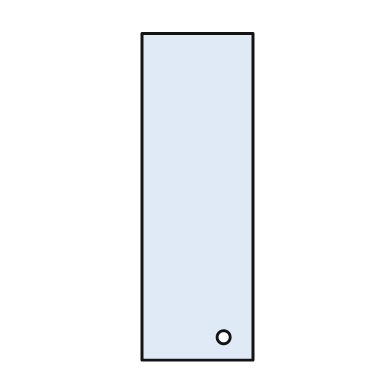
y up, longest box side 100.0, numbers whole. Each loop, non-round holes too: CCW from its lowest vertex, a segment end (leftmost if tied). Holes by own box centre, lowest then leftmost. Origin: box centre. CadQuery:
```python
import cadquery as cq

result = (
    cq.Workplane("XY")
    .moveTo(-17.0, -50.0)
    .lineTo(17.0, -50.0)
    .lineTo(17.0, 50.0)
    .lineTo(-17.0, 50.0)
    .close()
    .moveTo(8.0, -43.0)
    .circle(2.0)
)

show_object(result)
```